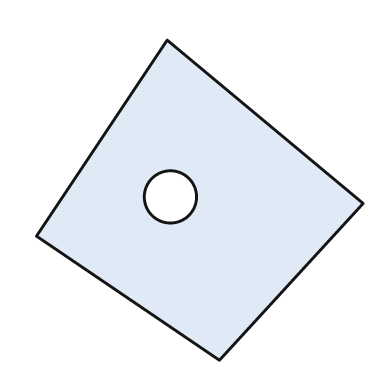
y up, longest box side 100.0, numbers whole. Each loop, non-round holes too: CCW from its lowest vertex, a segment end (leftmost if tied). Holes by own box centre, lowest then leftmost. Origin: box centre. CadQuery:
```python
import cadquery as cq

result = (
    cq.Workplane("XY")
    .moveTo(6.0, -49.0)
    .lineTo(50.0, -1.0)
    .lineTo(-10.0, 49.0)
    .lineTo(-50.0, -11.0)
    .close()
    .moveTo(-9.0, 1.0)
    .circle(8.0)
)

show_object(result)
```